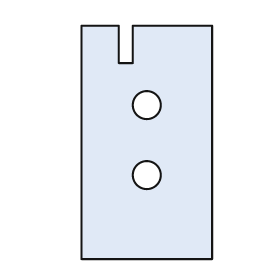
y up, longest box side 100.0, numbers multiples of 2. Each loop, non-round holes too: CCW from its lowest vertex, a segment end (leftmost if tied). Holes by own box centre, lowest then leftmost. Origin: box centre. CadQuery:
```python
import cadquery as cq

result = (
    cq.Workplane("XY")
    .moveTo(-28.0, -50.0)
    .lineTo(28.0, -50.0)
    .lineTo(28.0, 50.0)
    .lineTo(-6.0, 50.0)
    .lineTo(-6.0, 34.0)
    .lineTo(-12.0, 34.0)
    .lineTo(-12.0, 50.0)
    .lineTo(-28.0, 50.0)
    .close()
    .moveTo(0.0, -14.0)
    .circle(6.0)
    .moveTo(0.0, 16.0)
    .circle(6.0)
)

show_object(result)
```